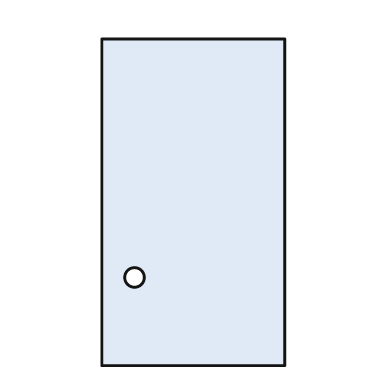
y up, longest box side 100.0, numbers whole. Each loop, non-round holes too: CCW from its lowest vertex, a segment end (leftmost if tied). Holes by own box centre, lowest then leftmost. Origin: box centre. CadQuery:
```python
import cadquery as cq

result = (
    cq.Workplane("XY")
    .moveTo(-28.0, -50.0)
    .lineTo(28.0, -50.0)
    .lineTo(28.0, 50.0)
    .lineTo(-28.0, 50.0)
    .close()
    .moveTo(-18.0, -23.0)
    .circle(3.0)
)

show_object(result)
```